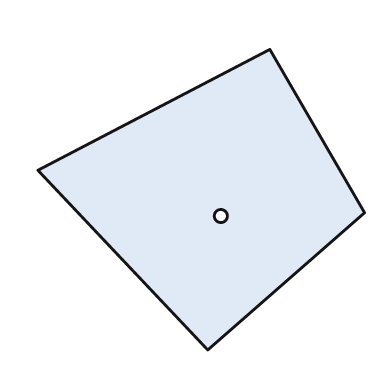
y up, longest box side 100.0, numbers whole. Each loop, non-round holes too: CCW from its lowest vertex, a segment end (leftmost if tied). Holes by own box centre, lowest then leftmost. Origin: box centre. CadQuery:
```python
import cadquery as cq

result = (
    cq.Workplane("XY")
    .moveTo(2.0, -46.0)
    .lineTo(50.0, -4.0)
    .lineTo(21.0, 46.0)
    .lineTo(-50.0, 9.0)
    .close()
    .moveTo(6.0, -5.0)
    .circle(2.0)
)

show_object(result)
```